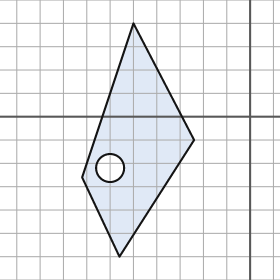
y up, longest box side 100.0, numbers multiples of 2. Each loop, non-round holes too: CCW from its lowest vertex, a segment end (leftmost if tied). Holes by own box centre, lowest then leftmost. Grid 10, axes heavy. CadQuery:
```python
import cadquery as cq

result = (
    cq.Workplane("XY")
    .moveTo(-56.0, -60.0)
    .lineTo(-24.0, -10.0)
    .lineTo(-50.0, 40.0)
    .lineTo(-72.0, -26.0)
    .close()
    .moveTo(-60.0, -22.0)
    .circle(6.0)
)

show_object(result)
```